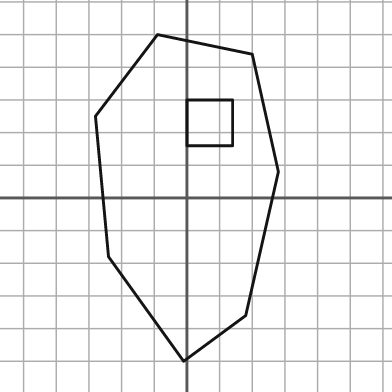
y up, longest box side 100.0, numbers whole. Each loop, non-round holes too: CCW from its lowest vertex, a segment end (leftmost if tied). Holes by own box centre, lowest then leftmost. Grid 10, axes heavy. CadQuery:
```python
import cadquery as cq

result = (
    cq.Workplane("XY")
    .moveTo(-1.0, -50.0)
    .lineTo(18.0, -36.0)
    .lineTo(28.0, 8.0)
    .lineTo(20.0, 44.0)
    .lineTo(-9.0, 50.0)
    .lineTo(-28.0, 25.0)
    .lineTo(-24.0, -18.0)
    .close()
    .moveTo(0.0, 16.0)
    .lineTo(14.0, 16.0)
    .lineTo(14.0, 30.0)
    .lineTo(0.0, 30.0)
    .close()
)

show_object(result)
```